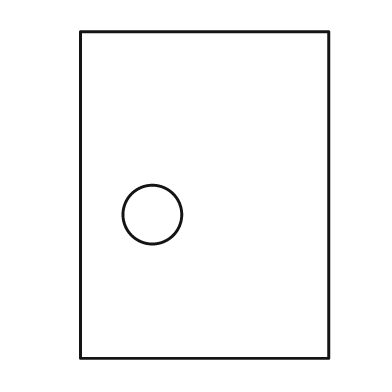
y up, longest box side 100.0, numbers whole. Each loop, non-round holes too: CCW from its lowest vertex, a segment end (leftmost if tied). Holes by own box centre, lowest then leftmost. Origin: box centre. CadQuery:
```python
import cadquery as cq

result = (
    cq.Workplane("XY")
    .moveTo(-38.0, -50.0)
    .lineTo(38.0, -50.0)
    .lineTo(38.0, 50.0)
    .lineTo(-38.0, 50.0)
    .close()
    .moveTo(-16.0, -6.0)
    .circle(9.0)
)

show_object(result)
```